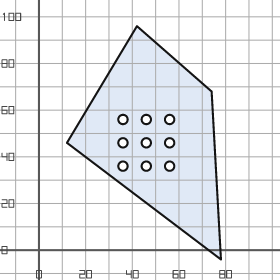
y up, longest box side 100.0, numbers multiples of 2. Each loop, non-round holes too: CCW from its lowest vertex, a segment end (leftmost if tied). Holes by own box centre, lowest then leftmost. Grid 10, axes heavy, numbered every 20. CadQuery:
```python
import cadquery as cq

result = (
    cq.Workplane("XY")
    .moveTo(78.0, -4.0)
    .lineTo(74.0, 68.0)
    .lineTo(42.0, 96.0)
    .lineTo(12.0, 46.0)
    .close()
    .moveTo(36.0, 36.0)
    .circle(2.0)
    .moveTo(46.0, 36.0)
    .circle(2.0)
    .moveTo(56.0, 36.0)
    .circle(2.0)
    .moveTo(36.0, 46.0)
    .circle(2.0)
    .moveTo(46.0, 46.0)
    .circle(2.0)
    .moveTo(56.0, 46.0)
    .circle(2.0)
    .moveTo(36.0, 56.0)
    .circle(2.0)
    .moveTo(46.0, 56.0)
    .circle(2.0)
    .moveTo(56.0, 56.0)
    .circle(2.0)
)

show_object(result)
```